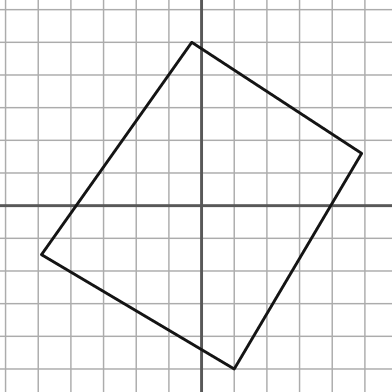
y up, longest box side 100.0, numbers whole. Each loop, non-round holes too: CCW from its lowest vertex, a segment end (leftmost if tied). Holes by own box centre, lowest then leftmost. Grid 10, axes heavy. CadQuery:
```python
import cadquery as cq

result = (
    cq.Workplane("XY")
    .moveTo(10.0, -50.0)
    .lineTo(49.0, 16.0)
    .lineTo(-3.0, 50.0)
    .lineTo(-49.0, -15.0)
    .close()
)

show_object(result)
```